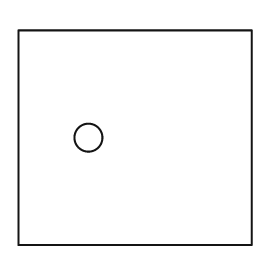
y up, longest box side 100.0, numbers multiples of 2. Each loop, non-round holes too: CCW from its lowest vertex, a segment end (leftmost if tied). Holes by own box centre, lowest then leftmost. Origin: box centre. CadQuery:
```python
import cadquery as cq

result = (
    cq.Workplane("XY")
    .moveTo(-50.0, -46.0)
    .lineTo(50.0, -46.0)
    .lineTo(50.0, 46.0)
    .lineTo(-50.0, 46.0)
    .close()
    .moveTo(-20.0, 0.0)
    .circle(6.0)
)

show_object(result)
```